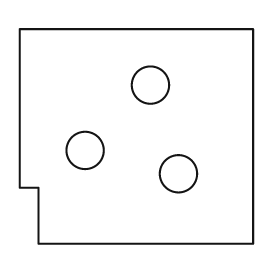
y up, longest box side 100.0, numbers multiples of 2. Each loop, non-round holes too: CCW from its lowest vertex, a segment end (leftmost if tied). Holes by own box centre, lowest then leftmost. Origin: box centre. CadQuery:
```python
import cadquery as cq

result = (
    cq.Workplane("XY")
    .moveTo(-42.0, -46.0)
    .lineTo(50.0, -46.0)
    .lineTo(50.0, 46.0)
    .lineTo(-50.0, 46.0)
    .lineTo(-50.0, -22.0)
    .lineTo(-42.0, -22.0)
    .close()
    .moveTo(18.0, -16.0)
    .circle(8.0)
    .moveTo(-22.0, -6.0)
    .circle(8.0)
    .moveTo(6.0, 22.0)
    .circle(8.0)
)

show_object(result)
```